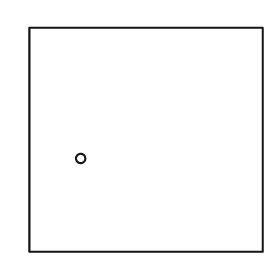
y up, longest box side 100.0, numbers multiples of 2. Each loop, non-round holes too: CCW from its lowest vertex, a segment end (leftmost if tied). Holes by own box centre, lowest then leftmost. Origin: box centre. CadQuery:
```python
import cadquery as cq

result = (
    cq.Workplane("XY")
    .moveTo(-50.0, -48.0)
    .lineTo(50.0, -48.0)
    .lineTo(50.0, 48.0)
    .lineTo(-50.0, 48.0)
    .close()
    .moveTo(-28.0, -8.0)
    .circle(2.0)
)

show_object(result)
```